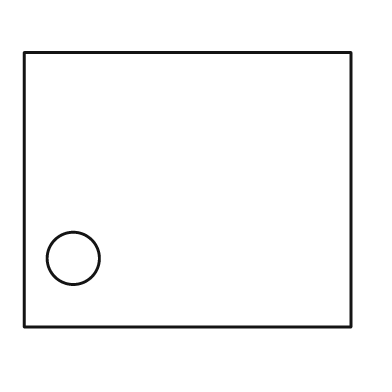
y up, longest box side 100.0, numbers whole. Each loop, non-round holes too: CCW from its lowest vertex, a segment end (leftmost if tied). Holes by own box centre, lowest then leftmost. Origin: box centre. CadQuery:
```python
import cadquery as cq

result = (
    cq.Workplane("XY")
    .moveTo(-50.0, -42.0)
    .lineTo(50.0, -42.0)
    .lineTo(50.0, 42.0)
    .lineTo(-50.0, 42.0)
    .close()
    .moveTo(-35.0, -21.0)
    .circle(8.0)
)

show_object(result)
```